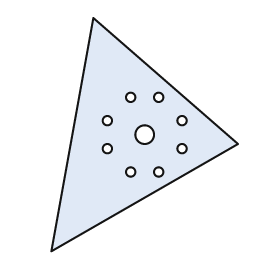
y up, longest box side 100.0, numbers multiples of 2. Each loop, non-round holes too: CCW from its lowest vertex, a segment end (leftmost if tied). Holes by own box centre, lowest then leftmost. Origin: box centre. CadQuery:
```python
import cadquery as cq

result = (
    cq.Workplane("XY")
    .moveTo(-40.0, -50.0)
    .lineTo(40.0, -4.0)
    .lineTo(-22.0, 50.0)
    .close()
    .moveTo(-6.0, -16.0)
    .circle(2.0)
    .moveTo(6.0, -16.0)
    .circle(2.0)
    .moveTo(-16.0, -6.0)
    .circle(2.0)
    .moveTo(16.0, -6.0)
    .circle(2.0)
    .moveTo(0.0, 0.0)
    .circle(4.0)
    .moveTo(-16.0, 6.0)
    .circle(2.0)
    .moveTo(16.0, 6.0)
    .circle(2.0)
    .moveTo(-6.0, 16.0)
    .circle(2.0)
    .moveTo(6.0, 16.0)
    .circle(2.0)
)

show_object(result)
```